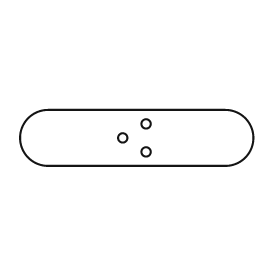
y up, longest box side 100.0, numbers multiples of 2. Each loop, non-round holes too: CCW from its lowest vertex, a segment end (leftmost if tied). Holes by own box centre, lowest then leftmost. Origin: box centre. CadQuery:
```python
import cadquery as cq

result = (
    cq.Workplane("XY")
    .moveTo(-38.0, -12.0)
    .lineTo(38.0, -12.0)
    .threePointArc((50.0, 0.0), (38.0, 12.0))
    .lineTo(-38.0, 12.0)
    .threePointArc((-50.0, 0.0), (-38.0, -12.0))
    .close()
    .moveTo(4.0, -6.0)
    .circle(2.0)
    .moveTo(-6.0, 0.0)
    .circle(2.0)
    .moveTo(4.0, 6.0)
    .circle(2.0)
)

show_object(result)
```